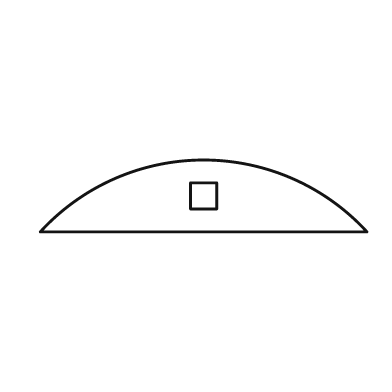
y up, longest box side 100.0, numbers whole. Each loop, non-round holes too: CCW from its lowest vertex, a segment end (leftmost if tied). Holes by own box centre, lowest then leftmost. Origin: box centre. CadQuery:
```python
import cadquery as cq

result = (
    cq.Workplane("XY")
    .moveTo(-50.0, -11.0)
    .lineTo(50.0, -11.0)
    .threePointArc((0.0, 11.0), (-50.0, -11.0))
    .close()
    .moveTo(-4.0, -4.0)
    .lineTo(4.0, -4.0)
    .lineTo(4.0, 4.0)
    .lineTo(-4.0, 4.0)
    .close()
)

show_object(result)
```